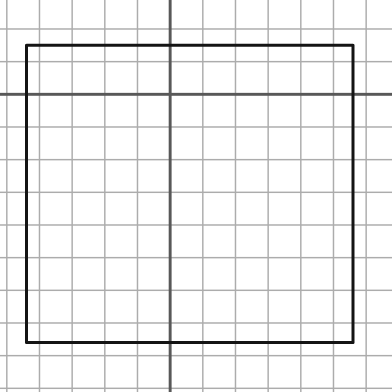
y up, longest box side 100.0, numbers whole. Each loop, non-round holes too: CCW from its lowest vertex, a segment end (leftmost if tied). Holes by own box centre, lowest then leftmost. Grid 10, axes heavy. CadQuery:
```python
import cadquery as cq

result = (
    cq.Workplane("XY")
    .moveTo(-44.0, -76.0)
    .lineTo(56.0, -76.0)
    .lineTo(56.0, 15.0)
    .lineTo(-44.0, 15.0)
    .close()
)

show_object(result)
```